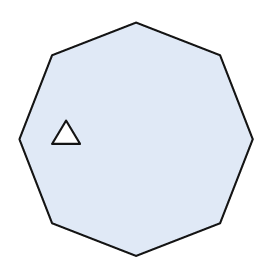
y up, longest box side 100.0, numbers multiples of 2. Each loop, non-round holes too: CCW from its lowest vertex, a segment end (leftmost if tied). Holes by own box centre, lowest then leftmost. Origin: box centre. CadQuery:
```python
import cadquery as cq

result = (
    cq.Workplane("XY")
    .moveTo(0.0, -50.0)
    .lineTo(36.0, -36.0)
    .lineTo(50.0, 0.0)
    .lineTo(36.0, 36.0)
    .lineTo(0.0, 50.0)
    .lineTo(-36.0, 36.0)
    .lineTo(-50.0, 0.0)
    .lineTo(-36.0, -36.0)
    .close()
    .moveTo(-36.0, -2.0)
    .lineTo(-24.0, -2.0)
    .lineTo(-30.0, 8.0)
    .close()
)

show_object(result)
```